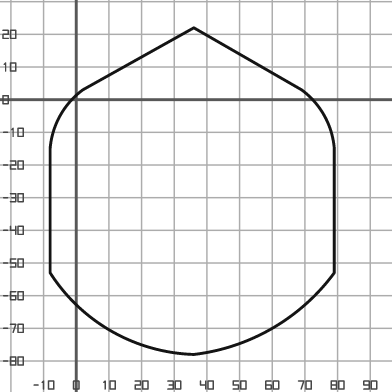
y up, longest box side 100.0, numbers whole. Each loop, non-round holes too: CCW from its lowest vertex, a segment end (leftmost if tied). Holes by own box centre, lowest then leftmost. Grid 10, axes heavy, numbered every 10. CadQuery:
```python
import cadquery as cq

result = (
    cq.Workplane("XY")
    .moveTo(36.0, -78.0)
    .threePointArc((60.0, -70.0), (79.0, -53.0))
    .lineTo(79.0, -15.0)
    .threePointArc((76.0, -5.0), (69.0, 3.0))
    .lineTo(36.0, 22.0)
    .lineTo(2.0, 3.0)
    .threePointArc((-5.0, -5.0), (-8.0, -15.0))
    .lineTo(-8.0, -53.0)
    .threePointArc((11.0, -71.0), (36.0, -78.0))
    .close()
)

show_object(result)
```